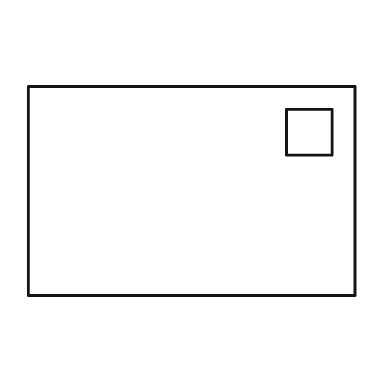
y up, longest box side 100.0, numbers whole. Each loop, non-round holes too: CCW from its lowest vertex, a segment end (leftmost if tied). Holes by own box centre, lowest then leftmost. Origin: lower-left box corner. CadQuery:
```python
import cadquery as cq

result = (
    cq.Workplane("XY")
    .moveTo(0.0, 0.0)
    .lineTo(100.0, 0.0)
    .lineTo(100.0, 64.0)
    .lineTo(0.0, 64.0)
    .close()
    .moveTo(79.0, 43.0)
    .lineTo(93.0, 43.0)
    .lineTo(93.0, 57.0)
    .lineTo(79.0, 57.0)
    .close()
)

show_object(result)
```